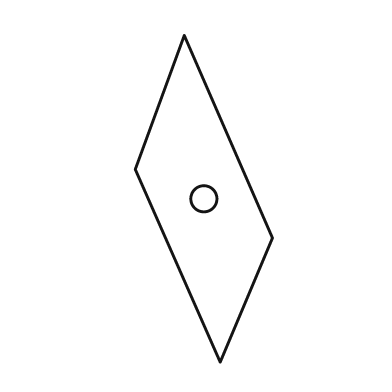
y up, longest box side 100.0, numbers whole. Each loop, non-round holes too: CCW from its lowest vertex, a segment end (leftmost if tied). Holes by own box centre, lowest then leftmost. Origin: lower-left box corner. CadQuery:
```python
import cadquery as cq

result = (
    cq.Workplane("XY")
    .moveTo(26.0, 0.0)
    .lineTo(42.0, 38.0)
    .lineTo(15.0, 100.0)
    .lineTo(0.0, 59.0)
    .close()
    .moveTo(21.0, 50.0)
    .circle(4.0)
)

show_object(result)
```